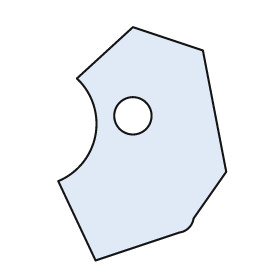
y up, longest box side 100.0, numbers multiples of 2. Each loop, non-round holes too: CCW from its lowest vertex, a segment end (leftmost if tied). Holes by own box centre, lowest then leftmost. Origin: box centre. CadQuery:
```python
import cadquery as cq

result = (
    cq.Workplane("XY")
    .moveTo(-20.0, -50.0)
    .lineTo(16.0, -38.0)
    .threePointArc((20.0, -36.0), (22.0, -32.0))
    .lineTo(36.0, -12.0)
    .lineTo(26.0, 40.0)
    .lineTo(-4.0, 50.0)
    .lineTo(-28.0, 28.0)
    .threePointArc((-20.0, 4.0), (-36.0, -16.0))
    .close()
    .moveTo(-4.0, 12.0)
    .circle(8.0)
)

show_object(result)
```